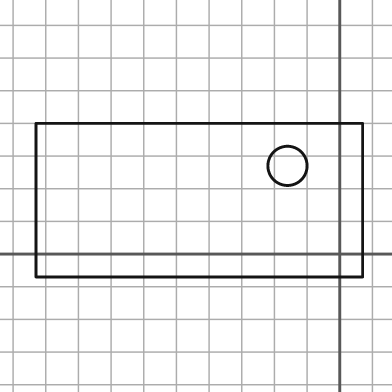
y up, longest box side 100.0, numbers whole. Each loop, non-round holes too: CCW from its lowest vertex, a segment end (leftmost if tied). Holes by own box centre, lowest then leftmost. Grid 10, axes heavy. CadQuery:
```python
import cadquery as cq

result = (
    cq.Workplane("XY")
    .moveTo(-93.0, -7.0)
    .lineTo(7.0, -7.0)
    .lineTo(7.0, 40.0)
    .lineTo(-93.0, 40.0)
    .close()
    .moveTo(-16.0, 27.0)
    .circle(6.0)
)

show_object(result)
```